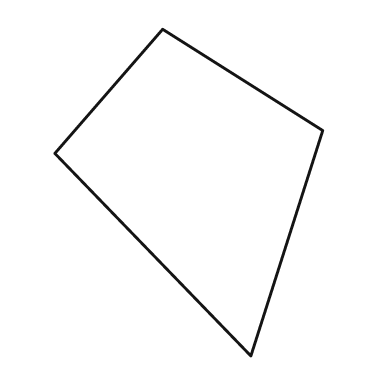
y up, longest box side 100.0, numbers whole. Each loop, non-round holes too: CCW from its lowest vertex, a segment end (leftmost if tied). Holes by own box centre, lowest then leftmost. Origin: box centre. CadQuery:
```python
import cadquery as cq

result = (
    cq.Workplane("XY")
    .moveTo(19.0, -50.0)
    .lineTo(41.0, 19.0)
    .lineTo(-8.0, 50.0)
    .lineTo(-41.0, 12.0)
    .close()
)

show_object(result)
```